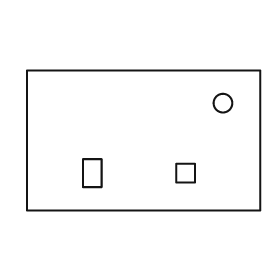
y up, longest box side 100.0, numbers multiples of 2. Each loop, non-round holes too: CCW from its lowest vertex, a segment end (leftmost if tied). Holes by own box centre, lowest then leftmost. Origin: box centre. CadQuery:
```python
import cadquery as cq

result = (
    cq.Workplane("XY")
    .moveTo(-50.0, -30.0)
    .lineTo(50.0, -30.0)
    .lineTo(50.0, 30.0)
    .lineTo(-50.0, 30.0)
    .close()
    .moveTo(-26.0, -20.0)
    .lineTo(-18.0, -20.0)
    .lineTo(-18.0, -8.0)
    .lineTo(-26.0, -8.0)
    .close()
    .moveTo(14.0, -18.0)
    .lineTo(22.0, -18.0)
    .lineTo(22.0, -10.0)
    .lineTo(14.0, -10.0)
    .close()
    .moveTo(34.0, 16.0)
    .circle(4.0)
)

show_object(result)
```